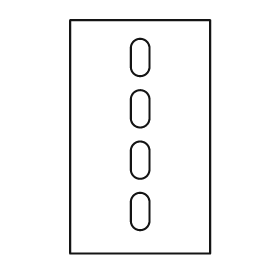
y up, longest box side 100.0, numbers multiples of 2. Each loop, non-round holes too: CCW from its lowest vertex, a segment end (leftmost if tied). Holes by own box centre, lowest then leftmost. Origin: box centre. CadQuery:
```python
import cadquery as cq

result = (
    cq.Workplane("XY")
    .moveTo(-30.0, -50.0)
    .lineTo(30.0, -50.0)
    .lineTo(30.0, 50.0)
    .lineTo(-30.0, 50.0)
    .close()
    .moveTo(-4.0, -36.0)
    .threePointArc((0.0, -40.0), (4.0, -36.0))
    .lineTo(4.0, -28.0)
    .threePointArc((0.0, -24.0), (-4.0, -28.0))
    .close()
    .moveTo(-4.0, -14.0)
    .threePointArc((0.0, -18.0), (4.0, -14.0))
    .lineTo(4.0, -6.0)
    .threePointArc((0.0, -2.0), (-4.0, -6.0))
    .close()
    .moveTo(-4.0, 8.0)
    .threePointArc((0.0, 4.0), (4.0, 8.0))
    .lineTo(4.0, 16.0)
    .threePointArc((0.0, 20.0), (-4.0, 16.0))
    .close()
    .moveTo(-4.0, 30.0)
    .threePointArc((0.0, 26.0), (4.0, 30.0))
    .lineTo(4.0, 38.0)
    .threePointArc((0.0, 42.0), (-4.0, 38.0))
    .close()
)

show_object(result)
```